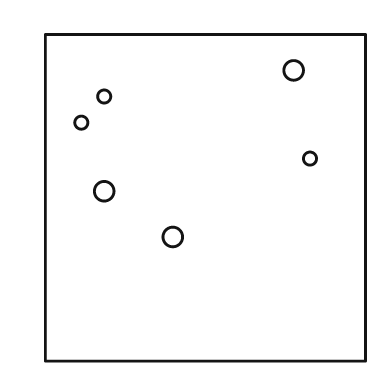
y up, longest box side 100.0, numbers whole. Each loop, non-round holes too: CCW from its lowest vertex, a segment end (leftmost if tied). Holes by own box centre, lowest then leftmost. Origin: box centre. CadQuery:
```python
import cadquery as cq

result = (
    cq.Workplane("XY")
    .moveTo(-49.0, -50.0)
    .lineTo(49.0, -50.0)
    .lineTo(49.0, 50.0)
    .lineTo(-49.0, 50.0)
    .close()
    .moveTo(-10.0, -12.0)
    .circle(3.0)
    .moveTo(-31.0, 2.0)
    .circle(3.0)
    .moveTo(32.0, 12.0)
    .circle(2.0)
    .moveTo(-38.0, 23.0)
    .circle(2.0)
    .moveTo(-31.0, 31.0)
    .circle(2.0)
    .moveTo(27.0, 39.0)
    .circle(3.0)
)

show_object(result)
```